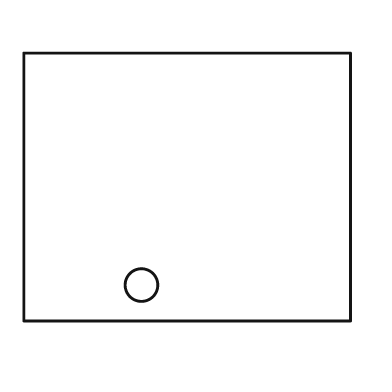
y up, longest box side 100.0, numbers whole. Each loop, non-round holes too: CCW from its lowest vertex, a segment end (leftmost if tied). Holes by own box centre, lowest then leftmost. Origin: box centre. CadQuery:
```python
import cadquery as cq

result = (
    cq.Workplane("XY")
    .moveTo(-50.0, -41.0)
    .lineTo(50.0, -41.0)
    .lineTo(50.0, 41.0)
    .lineTo(-50.0, 41.0)
    .close()
    .moveTo(-14.0, -30.0)
    .circle(5.0)
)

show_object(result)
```